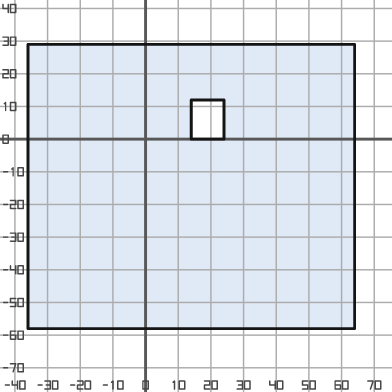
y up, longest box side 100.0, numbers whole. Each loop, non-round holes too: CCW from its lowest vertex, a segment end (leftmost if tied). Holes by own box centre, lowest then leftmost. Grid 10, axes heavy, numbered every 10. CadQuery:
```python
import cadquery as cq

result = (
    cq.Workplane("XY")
    .moveTo(-36.0, -58.0)
    .lineTo(64.0, -58.0)
    .lineTo(64.0, 29.0)
    .lineTo(-36.0, 29.0)
    .close()
    .moveTo(14.0, 0.0)
    .lineTo(24.0, 0.0)
    .lineTo(24.0, 12.0)
    .lineTo(14.0, 12.0)
    .close()
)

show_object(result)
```